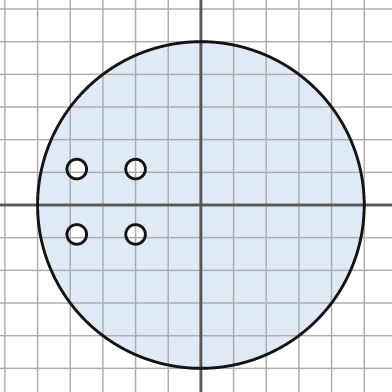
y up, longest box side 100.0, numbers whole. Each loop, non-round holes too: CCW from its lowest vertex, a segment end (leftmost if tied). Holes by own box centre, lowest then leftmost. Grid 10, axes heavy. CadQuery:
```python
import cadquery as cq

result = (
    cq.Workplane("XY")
    .moveTo(0.0, 0.0)
    .circle(50.0)
    .moveTo(-38.0, -9.0)
    .circle(3.0)
    .moveTo(-20.0, -9.0)
    .circle(3.0)
    .moveTo(-38.0, 11.0)
    .circle(3.0)
    .moveTo(-20.0, 11.0)
    .circle(3.0)
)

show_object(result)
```